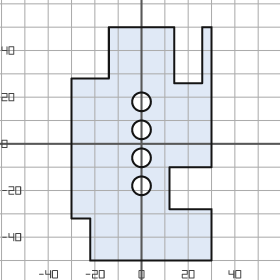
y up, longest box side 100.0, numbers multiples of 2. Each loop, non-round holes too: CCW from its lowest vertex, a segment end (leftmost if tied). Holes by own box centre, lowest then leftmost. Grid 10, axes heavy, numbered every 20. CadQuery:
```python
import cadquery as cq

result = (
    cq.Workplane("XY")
    .moveTo(-22.0, -50.0)
    .lineTo(30.0, -50.0)
    .lineTo(30.0, -28.0)
    .lineTo(12.0, -28.0)
    .lineTo(12.0, -10.0)
    .lineTo(30.0, -10.0)
    .lineTo(30.0, 50.0)
    .lineTo(26.0, 50.0)
    .lineTo(26.0, 26.0)
    .lineTo(14.0, 26.0)
    .lineTo(14.0, 50.0)
    .lineTo(-14.0, 50.0)
    .lineTo(-14.0, 28.0)
    .lineTo(-30.0, 28.0)
    .lineTo(-30.0, -32.0)
    .lineTo(-22.0, -32.0)
    .close()
    .moveTo(0.0, -18.0)
    .circle(4.0)
    .moveTo(0.0, -6.0)
    .circle(4.0)
    .moveTo(0.0, 6.0)
    .circle(4.0)
    .moveTo(0.0, 18.0)
    .circle(4.0)
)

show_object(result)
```